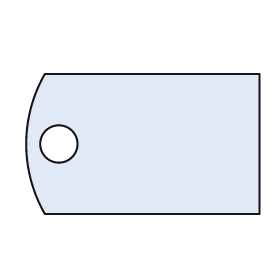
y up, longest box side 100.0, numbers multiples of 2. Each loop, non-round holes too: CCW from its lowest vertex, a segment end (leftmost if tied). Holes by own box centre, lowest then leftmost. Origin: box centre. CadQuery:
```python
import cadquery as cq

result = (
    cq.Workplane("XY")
    .moveTo(-42.0, -30.0)
    .lineTo(50.0, -30.0)
    .lineTo(50.0, 30.0)
    .lineTo(-42.0, 30.0)
    .threePointArc((-50.0, 0.0), (-42.0, -30.0))
    .close()
    .moveTo(-36.0, 0.0)
    .circle(8.0)
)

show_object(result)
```